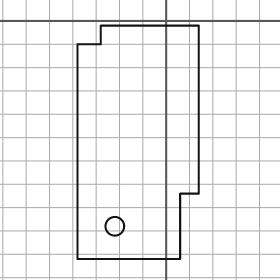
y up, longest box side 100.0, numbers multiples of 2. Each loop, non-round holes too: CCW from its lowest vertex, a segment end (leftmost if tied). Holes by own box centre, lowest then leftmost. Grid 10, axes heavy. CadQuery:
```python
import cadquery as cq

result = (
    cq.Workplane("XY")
    .moveTo(-38.0, -102.0)
    .lineTo(6.0, -102.0)
    .lineTo(6.0, -74.0)
    .lineTo(14.0, -74.0)
    .lineTo(14.0, -2.0)
    .lineTo(-28.0, -2.0)
    .lineTo(-28.0, -10.0)
    .lineTo(-38.0, -10.0)
    .close()
    .moveTo(-22.0, -88.0)
    .circle(4.0)
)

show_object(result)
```